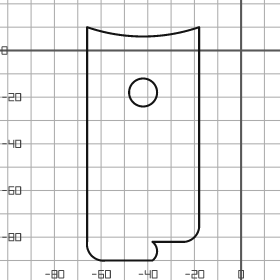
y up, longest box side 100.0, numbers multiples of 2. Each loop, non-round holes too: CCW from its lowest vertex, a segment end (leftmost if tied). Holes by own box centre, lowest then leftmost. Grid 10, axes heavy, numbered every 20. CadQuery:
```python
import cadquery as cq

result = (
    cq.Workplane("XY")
    .moveTo(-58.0, -90.0)
    .lineTo(-38.0, -90.0)
    .threePointArc((-36.0, -86.0), (-38.0, -82.0))
    .lineTo(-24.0, -82.0)
    .threePointArc((-20.0, -80.0), (-18.0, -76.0))
    .lineTo(-18.0, 10.0)
    .threePointArc((-42.0, 6.0), (-66.0, 10.0))
    .lineTo(-66.0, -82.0)
    .threePointArc((-64.0, -88.0), (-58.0, -90.0))
    .close()
    .moveTo(-42.0, -18.0)
    .circle(6.0)
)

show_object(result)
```